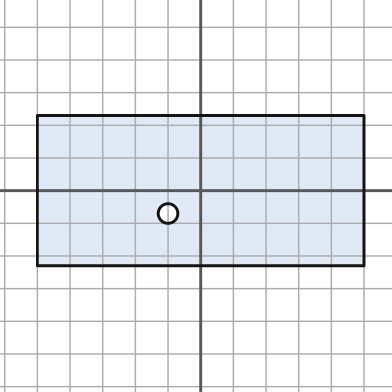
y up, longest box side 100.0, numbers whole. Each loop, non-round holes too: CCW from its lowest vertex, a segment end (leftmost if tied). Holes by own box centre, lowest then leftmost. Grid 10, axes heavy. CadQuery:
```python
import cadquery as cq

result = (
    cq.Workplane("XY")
    .moveTo(-50.0, -23.0)
    .lineTo(50.0, -23.0)
    .lineTo(50.0, 23.0)
    .lineTo(-50.0, 23.0)
    .close()
    .moveTo(-10.0, -7.0)
    .circle(3.0)
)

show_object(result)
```